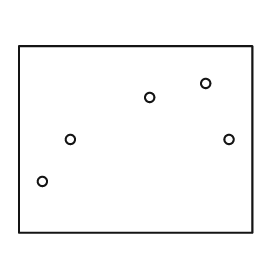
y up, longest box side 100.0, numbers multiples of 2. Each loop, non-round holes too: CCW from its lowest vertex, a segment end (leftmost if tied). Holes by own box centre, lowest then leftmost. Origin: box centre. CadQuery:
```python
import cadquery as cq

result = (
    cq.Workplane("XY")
    .moveTo(-50.0, -40.0)
    .lineTo(50.0, -40.0)
    .lineTo(50.0, 40.0)
    .lineTo(-50.0, 40.0)
    .close()
    .moveTo(-40.0, -18.0)
    .circle(2.0)
    .moveTo(-28.0, 0.0)
    .circle(2.0)
    .moveTo(40.0, 0.0)
    .circle(2.0)
    .moveTo(6.0, 18.0)
    .circle(2.0)
    .moveTo(30.0, 24.0)
    .circle(2.0)
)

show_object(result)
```